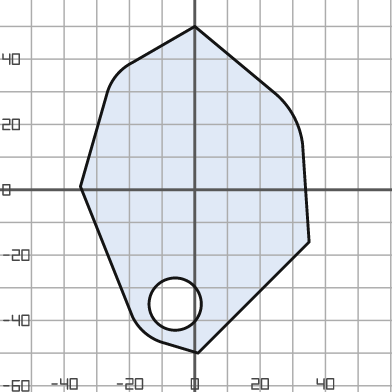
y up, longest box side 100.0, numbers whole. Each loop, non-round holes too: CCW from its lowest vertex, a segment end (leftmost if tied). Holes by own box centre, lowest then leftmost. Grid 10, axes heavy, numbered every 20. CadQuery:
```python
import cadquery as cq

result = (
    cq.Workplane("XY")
    .moveTo(1.0, -50.0)
    .lineTo(35.0, -16.0)
    .lineTo(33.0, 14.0)
    .threePointArc((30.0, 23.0), (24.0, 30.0))
    .lineTo(0.0, 50.0)
    .lineTo(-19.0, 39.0)
    .threePointArc((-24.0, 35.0), (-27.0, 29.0))
    .lineTo(-35.0, 1.0)
    .lineTo(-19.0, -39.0)
    .threePointArc((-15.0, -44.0), (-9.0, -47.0))
    .close()
    .moveTo(-6.0, -35.0)
    .circle(8.0)
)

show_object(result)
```